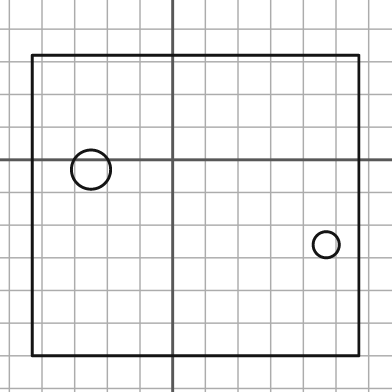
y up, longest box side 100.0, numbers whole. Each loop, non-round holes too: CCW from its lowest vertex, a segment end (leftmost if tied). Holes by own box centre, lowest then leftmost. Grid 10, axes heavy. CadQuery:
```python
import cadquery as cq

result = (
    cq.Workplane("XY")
    .moveTo(-43.0, -60.0)
    .lineTo(57.0, -60.0)
    .lineTo(57.0, 32.0)
    .lineTo(-43.0, 32.0)
    .close()
    .moveTo(47.0, -26.0)
    .circle(4.0)
    .moveTo(-25.0, -3.0)
    .circle(6.0)
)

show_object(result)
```